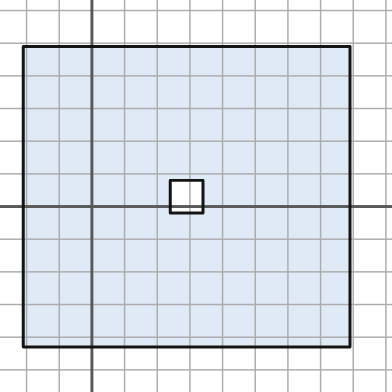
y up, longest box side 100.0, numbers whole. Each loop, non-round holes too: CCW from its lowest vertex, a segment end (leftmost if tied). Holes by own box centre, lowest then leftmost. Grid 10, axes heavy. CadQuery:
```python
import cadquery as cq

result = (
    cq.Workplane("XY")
    .moveTo(-21.0, -43.0)
    .lineTo(79.0, -43.0)
    .lineTo(79.0, 49.0)
    .lineTo(-21.0, 49.0)
    .close()
    .moveTo(24.0, -2.0)
    .lineTo(34.0, -2.0)
    .lineTo(34.0, 8.0)
    .lineTo(24.0, 8.0)
    .close()
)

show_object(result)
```